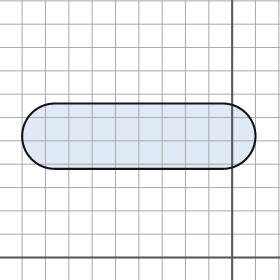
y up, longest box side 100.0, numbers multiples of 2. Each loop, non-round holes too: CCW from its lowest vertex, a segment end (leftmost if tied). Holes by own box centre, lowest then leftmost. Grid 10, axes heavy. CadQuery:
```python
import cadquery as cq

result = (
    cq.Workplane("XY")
    .moveTo(-76.0, 38.0)
    .lineTo(-4.0, 38.0)
    .threePointArc((10.0, 52.0), (-4.0, 66.0))
    .lineTo(-76.0, 66.0)
    .threePointArc((-90.0, 52.0), (-76.0, 38.0))
    .close()
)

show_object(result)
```